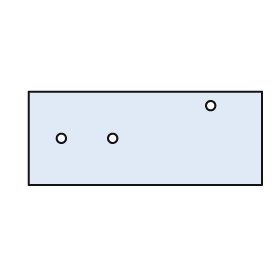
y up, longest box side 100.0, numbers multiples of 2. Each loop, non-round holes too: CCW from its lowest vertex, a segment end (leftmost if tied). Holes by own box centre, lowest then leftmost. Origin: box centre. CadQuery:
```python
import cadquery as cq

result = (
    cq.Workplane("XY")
    .moveTo(-50.0, -20.0)
    .lineTo(50.0, -20.0)
    .lineTo(50.0, 20.0)
    .lineTo(-50.0, 20.0)
    .close()
    .moveTo(-36.0, 0.0)
    .circle(2.0)
    .moveTo(-14.0, 0.0)
    .circle(2.0)
    .moveTo(28.0, 14.0)
    .circle(2.0)
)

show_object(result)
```